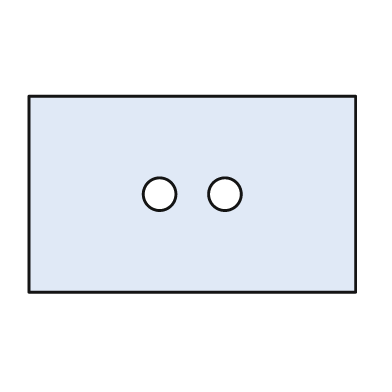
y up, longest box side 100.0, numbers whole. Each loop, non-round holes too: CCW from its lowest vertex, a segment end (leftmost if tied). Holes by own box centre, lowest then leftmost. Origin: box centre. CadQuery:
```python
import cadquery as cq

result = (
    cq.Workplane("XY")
    .moveTo(-50.0, -30.0)
    .lineTo(50.0, -30.0)
    .lineTo(50.0, 30.0)
    .lineTo(-50.0, 30.0)
    .close()
    .moveTo(-10.0, 0.0)
    .circle(5.0)
    .moveTo(10.0, 0.0)
    .circle(5.0)
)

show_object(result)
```